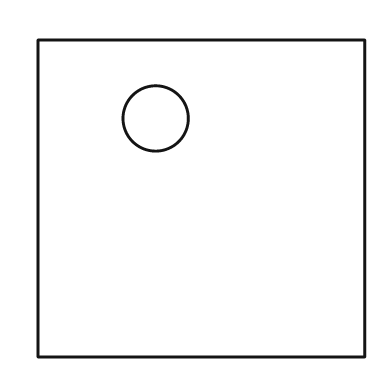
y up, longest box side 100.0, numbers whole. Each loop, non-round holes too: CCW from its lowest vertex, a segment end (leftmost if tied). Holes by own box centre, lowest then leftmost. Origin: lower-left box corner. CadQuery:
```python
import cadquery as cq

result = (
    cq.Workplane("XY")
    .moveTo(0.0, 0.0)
    .lineTo(100.0, 0.0)
    .lineTo(100.0, 97.0)
    .lineTo(0.0, 97.0)
    .close()
    .moveTo(36.0, 73.0)
    .circle(10.0)
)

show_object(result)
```